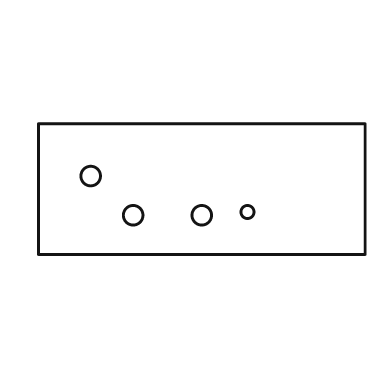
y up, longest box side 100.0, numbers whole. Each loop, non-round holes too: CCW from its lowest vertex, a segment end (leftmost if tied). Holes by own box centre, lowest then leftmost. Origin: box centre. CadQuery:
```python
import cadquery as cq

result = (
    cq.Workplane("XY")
    .moveTo(-50.0, -20.0)
    .lineTo(50.0, -20.0)
    .lineTo(50.0, 20.0)
    .lineTo(-50.0, 20.0)
    .close()
    .moveTo(-21.0, -8.0)
    .circle(3.0)
    .moveTo(0.0, -8.0)
    .circle(3.0)
    .moveTo(14.0, -7.0)
    .circle(2.0)
    .moveTo(-34.0, 4.0)
    .circle(3.0)
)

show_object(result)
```